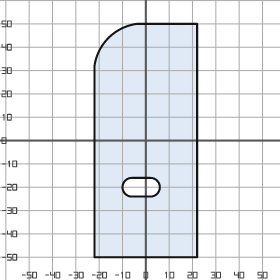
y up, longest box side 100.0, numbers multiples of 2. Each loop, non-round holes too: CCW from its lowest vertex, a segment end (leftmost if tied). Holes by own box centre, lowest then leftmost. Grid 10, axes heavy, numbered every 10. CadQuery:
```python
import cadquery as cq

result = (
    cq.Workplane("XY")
    .moveTo(-22.0, -50.0)
    .lineTo(22.0, -50.0)
    .lineTo(22.0, 50.0)
    .lineTo(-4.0, 50.0)
    .threePointArc((-16.0, 44.0), (-22.0, 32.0))
    .close()
    .moveTo(-6.0, -24.0)
    .lineTo(2.0, -24.0)
    .threePointArc((6.0, -20.0), (2.0, -16.0))
    .lineTo(-6.0, -16.0)
    .threePointArc((-10.0, -20.0), (-6.0, -24.0))
    .close()
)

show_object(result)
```